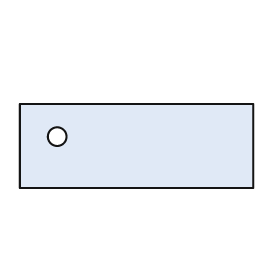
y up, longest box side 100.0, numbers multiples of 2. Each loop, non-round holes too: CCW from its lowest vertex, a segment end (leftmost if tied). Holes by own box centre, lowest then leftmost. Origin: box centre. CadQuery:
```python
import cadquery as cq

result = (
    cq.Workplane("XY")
    .moveTo(-50.0, -18.0)
    .lineTo(50.0, -18.0)
    .lineTo(50.0, 18.0)
    .lineTo(-50.0, 18.0)
    .close()
    .moveTo(-34.0, 4.0)
    .circle(4.0)
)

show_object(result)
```